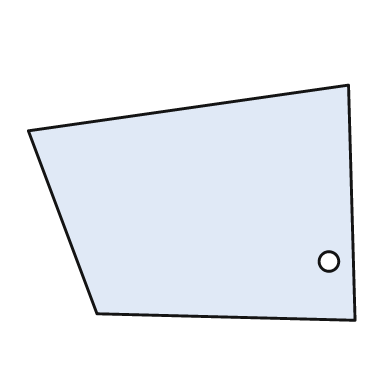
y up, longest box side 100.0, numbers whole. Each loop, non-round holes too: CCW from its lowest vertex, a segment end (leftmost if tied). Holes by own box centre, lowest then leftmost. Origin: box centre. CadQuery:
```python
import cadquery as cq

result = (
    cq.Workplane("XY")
    .moveTo(50.0, -36.0)
    .lineTo(48.0, 36.0)
    .lineTo(-50.0, 22.0)
    .lineTo(-29.0, -34.0)
    .close()
    .moveTo(42.0, -18.0)
    .circle(3.0)
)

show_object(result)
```